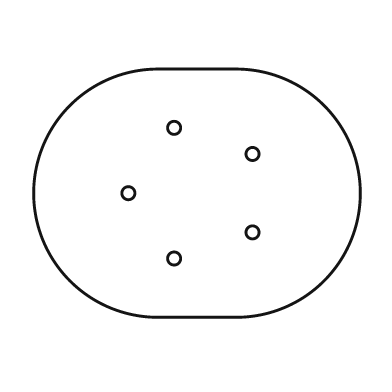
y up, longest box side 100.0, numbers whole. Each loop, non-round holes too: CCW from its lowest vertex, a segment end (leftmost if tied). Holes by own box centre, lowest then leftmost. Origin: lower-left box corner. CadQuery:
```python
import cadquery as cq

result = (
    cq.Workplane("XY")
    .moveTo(38.0, 0.0)
    .lineTo(62.0, 0.0)
    .threePointArc((100.0, 38.0), (62.0, 76.0))
    .lineTo(38.0, 76.0)
    .threePointArc((0.0, 38.0), (38.0, 0.0))
    .close()
    .moveTo(43.0, 18.0)
    .circle(2.0)
    .moveTo(67.0, 26.0)
    .circle(2.0)
    .moveTo(29.0, 38.0)
    .circle(2.0)
    .moveTo(67.0, 50.0)
    .circle(2.0)
    .moveTo(43.0, 58.0)
    .circle(2.0)
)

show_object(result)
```